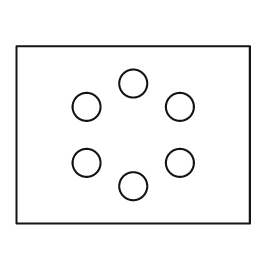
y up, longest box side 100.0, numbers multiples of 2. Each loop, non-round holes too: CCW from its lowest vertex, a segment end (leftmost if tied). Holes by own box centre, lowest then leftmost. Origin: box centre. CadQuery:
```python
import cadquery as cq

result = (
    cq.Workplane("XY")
    .moveTo(-50.0, -38.0)
    .lineTo(50.0, -38.0)
    .lineTo(50.0, 38.0)
    .lineTo(-50.0, 38.0)
    .close()
    .moveTo(0.0, -22.0)
    .circle(6.0)
    .moveTo(-20.0, -12.0)
    .circle(6.0)
    .moveTo(20.0, -12.0)
    .circle(6.0)
    .moveTo(-20.0, 12.0)
    .circle(6.0)
    .moveTo(20.0, 12.0)
    .circle(6.0)
    .moveTo(0.0, 22.0)
    .circle(6.0)
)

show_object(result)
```